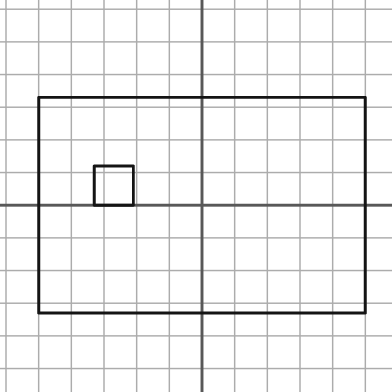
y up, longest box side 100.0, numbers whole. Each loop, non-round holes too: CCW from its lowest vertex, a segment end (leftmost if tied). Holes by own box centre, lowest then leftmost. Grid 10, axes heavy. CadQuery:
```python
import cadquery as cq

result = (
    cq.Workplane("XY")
    .moveTo(-50.0, -33.0)
    .lineTo(50.0, -33.0)
    .lineTo(50.0, 33.0)
    .lineTo(-50.0, 33.0)
    .close()
    .moveTo(-33.0, 0.0)
    .lineTo(-21.0, 0.0)
    .lineTo(-21.0, 12.0)
    .lineTo(-33.0, 12.0)
    .close()
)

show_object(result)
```